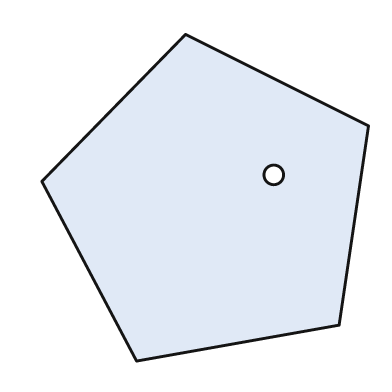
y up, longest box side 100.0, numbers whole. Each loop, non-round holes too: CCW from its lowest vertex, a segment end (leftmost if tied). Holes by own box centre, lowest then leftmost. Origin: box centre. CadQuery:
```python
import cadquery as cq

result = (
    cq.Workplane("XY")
    .moveTo(-21.0, -50.0)
    .lineTo(41.0, -39.0)
    .lineTo(50.0, 22.0)
    .lineTo(-6.0, 50.0)
    .lineTo(-50.0, 5.0)
    .close()
    .moveTo(21.0, 7.0)
    .circle(3.0)
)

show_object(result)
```